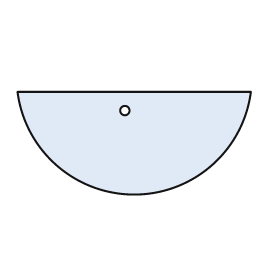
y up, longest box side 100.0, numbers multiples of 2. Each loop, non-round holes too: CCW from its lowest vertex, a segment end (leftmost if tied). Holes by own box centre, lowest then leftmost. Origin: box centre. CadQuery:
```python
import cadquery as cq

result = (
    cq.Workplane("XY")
    .moveTo(-50.0, 22.0)
    .threePointArc((0.0, -22.0), (50.0, 22.0))
    .close()
    .moveTo(-4.0, 14.0)
    .circle(2.0)
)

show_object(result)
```